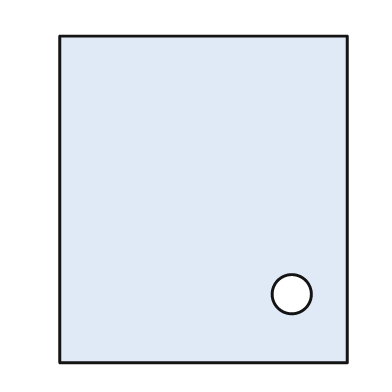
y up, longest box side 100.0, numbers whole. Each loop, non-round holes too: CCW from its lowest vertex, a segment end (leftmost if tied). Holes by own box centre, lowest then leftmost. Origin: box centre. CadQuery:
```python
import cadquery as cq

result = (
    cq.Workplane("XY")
    .moveTo(-44.0, -50.0)
    .lineTo(44.0, -50.0)
    .lineTo(44.0, 50.0)
    .lineTo(-44.0, 50.0)
    .close()
    .moveTo(27.0, -29.0)
    .circle(6.0)
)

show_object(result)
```